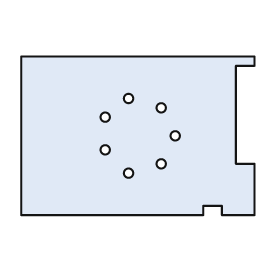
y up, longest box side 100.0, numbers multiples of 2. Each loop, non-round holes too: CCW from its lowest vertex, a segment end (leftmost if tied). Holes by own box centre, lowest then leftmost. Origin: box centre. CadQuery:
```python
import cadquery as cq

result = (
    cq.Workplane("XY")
    .moveTo(-50.0, -34.0)
    .lineTo(28.0, -34.0)
    .lineTo(28.0, -30.0)
    .lineTo(36.0, -30.0)
    .lineTo(36.0, -34.0)
    .lineTo(50.0, -34.0)
    .lineTo(50.0, -12.0)
    .lineTo(42.0, -12.0)
    .lineTo(42.0, 30.0)
    .lineTo(50.0, 30.0)
    .lineTo(50.0, 34.0)
    .lineTo(-50.0, 34.0)
    .close()
    .moveTo(-4.0, -16.0)
    .circle(2.0)
    .moveTo(10.0, -12.0)
    .circle(2.0)
    .moveTo(-14.0, -6.0)
    .circle(2.0)
    .moveTo(16.0, 0.0)
    .circle(2.0)
    .moveTo(-14.0, 8.0)
    .circle(2.0)
    .moveTo(10.0, 12.0)
    .circle(2.0)
    .moveTo(-4.0, 16.0)
    .circle(2.0)
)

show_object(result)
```